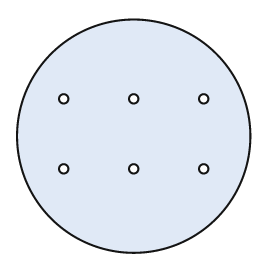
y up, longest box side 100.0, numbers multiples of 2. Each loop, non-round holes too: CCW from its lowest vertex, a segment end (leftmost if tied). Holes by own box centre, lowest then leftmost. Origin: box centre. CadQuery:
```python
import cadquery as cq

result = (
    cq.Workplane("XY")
    .moveTo(0.0, 0.0)
    .circle(50.0)
    .moveTo(-30.0, -14.0)
    .circle(2.0)
    .moveTo(0.0, -14.0)
    .circle(2.0)
    .moveTo(30.0, -14.0)
    .circle(2.0)
    .moveTo(-30.0, 16.0)
    .circle(2.0)
    .moveTo(0.0, 16.0)
    .circle(2.0)
    .moveTo(30.0, 16.0)
    .circle(2.0)
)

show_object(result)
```